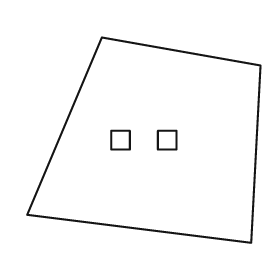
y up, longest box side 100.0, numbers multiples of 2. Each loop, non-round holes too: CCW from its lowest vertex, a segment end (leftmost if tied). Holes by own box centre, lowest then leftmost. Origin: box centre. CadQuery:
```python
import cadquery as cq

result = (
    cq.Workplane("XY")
    .moveTo(46.0, -44.0)
    .lineTo(50.0, 32.0)
    .lineTo(-18.0, 44.0)
    .lineTo(-50.0, -32.0)
    .close()
    .moveTo(-14.0, -4.0)
    .lineTo(-6.0, -4.0)
    .lineTo(-6.0, 4.0)
    .lineTo(-14.0, 4.0)
    .close()
    .moveTo(6.0, -4.0)
    .lineTo(14.0, -4.0)
    .lineTo(14.0, 4.0)
    .lineTo(6.0, 4.0)
    .close()
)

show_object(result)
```